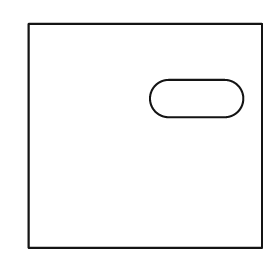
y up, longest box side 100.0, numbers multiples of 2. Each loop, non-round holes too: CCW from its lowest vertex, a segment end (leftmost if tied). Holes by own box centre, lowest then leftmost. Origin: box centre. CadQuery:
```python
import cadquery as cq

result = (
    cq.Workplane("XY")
    .moveTo(-50.0, -48.0)
    .lineTo(50.0, -48.0)
    .lineTo(50.0, 48.0)
    .lineTo(-50.0, 48.0)
    .close()
    .moveTo(10.0, 8.0)
    .lineTo(34.0, 8.0)
    .threePointArc((42.0, 16.0), (34.0, 24.0))
    .lineTo(10.0, 24.0)
    .threePointArc((2.0, 16.0), (10.0, 8.0))
    .close()
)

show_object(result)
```